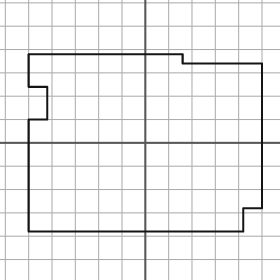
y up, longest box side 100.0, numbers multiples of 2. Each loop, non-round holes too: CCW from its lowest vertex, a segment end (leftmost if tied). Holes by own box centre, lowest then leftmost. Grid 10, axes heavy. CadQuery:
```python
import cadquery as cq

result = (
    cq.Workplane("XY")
    .moveTo(-50.0, -38.0)
    .lineTo(42.0, -38.0)
    .lineTo(42.0, -28.0)
    .lineTo(50.0, -28.0)
    .lineTo(50.0, 34.0)
    .lineTo(16.0, 34.0)
    .lineTo(16.0, 38.0)
    .lineTo(-50.0, 38.0)
    .lineTo(-50.0, 24.0)
    .lineTo(-42.0, 24.0)
    .lineTo(-42.0, 10.0)
    .lineTo(-50.0, 10.0)
    .close()
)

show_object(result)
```